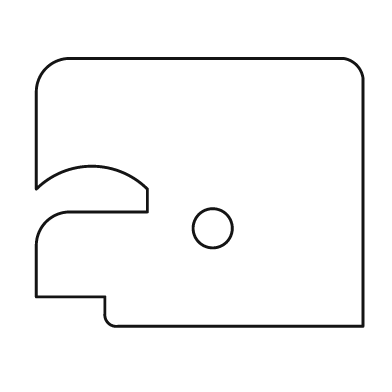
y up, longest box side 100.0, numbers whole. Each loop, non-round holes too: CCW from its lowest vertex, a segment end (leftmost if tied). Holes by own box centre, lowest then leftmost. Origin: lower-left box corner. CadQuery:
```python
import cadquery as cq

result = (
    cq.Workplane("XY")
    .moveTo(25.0, 0.0)
    .lineTo(100.0, 0.0)
    .lineTo(100.0, 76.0)
    .threePointArc((98.0, 80.0), (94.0, 82.0))
    .lineTo(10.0, 82.0)
    .threePointArc((3.0, 79.0), (0.0, 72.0))
    .lineTo(0.0, 42.0)
    .threePointArc((17.0, 49.0), (34.0, 42.0))
    .lineTo(34.0, 35.0)
    .lineTo(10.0, 35.0)
    .threePointArc((3.0, 32.0), (0.0, 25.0))
    .lineTo(0.0, 9.0)
    .lineTo(21.0, 9.0)
    .lineTo(21.0, 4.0)
    .threePointArc((22.0, 1.0), (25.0, 0.0))
    .close()
    .moveTo(54.0, 30.0)
    .circle(6.0)
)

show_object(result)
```